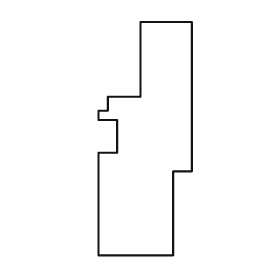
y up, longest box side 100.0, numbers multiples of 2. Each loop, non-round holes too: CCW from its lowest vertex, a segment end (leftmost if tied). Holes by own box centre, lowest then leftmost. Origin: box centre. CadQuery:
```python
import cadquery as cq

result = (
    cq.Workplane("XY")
    .moveTo(-20.0, -50.0)
    .lineTo(12.0, -50.0)
    .lineTo(12.0, -14.0)
    .lineTo(20.0, -14.0)
    .lineTo(20.0, 50.0)
    .lineTo(-2.0, 50.0)
    .lineTo(-2.0, 18.0)
    .lineTo(-16.0, 18.0)
    .lineTo(-16.0, 12.0)
    .lineTo(-20.0, 12.0)
    .lineTo(-20.0, 8.0)
    .lineTo(-12.0, 8.0)
    .lineTo(-12.0, -6.0)
    .lineTo(-20.0, -6.0)
    .close()
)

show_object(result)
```